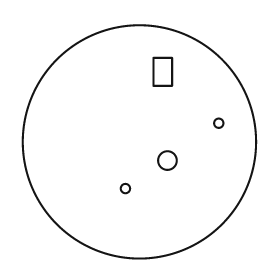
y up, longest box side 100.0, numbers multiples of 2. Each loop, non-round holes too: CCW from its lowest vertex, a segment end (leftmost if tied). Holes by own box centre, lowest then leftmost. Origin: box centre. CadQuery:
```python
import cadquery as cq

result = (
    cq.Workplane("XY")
    .moveTo(0.0, 0.0)
    .circle(50.0)
    .moveTo(-6.0, -20.0)
    .circle(2.0)
    .moveTo(12.0, -8.0)
    .circle(4.0)
    .moveTo(34.0, 8.0)
    .circle(2.0)
    .moveTo(6.0, 24.0)
    .lineTo(14.0, 24.0)
    .lineTo(14.0, 36.0)
    .lineTo(6.0, 36.0)
    .close()
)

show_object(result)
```